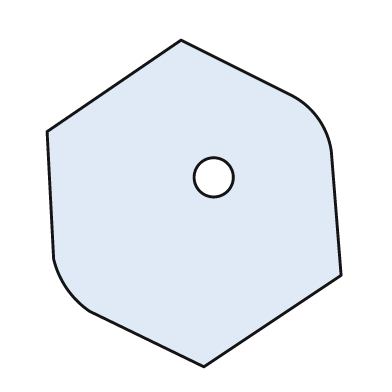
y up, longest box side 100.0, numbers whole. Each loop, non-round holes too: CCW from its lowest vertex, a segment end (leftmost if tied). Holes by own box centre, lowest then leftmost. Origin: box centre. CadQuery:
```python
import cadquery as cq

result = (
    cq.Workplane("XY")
    .moveTo(3.0, -50.0)
    .lineTo(45.0, -22.0)
    .lineTo(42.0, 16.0)
    .threePointArc((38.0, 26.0), (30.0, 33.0))
    .lineTo(-4.0, 50.0)
    .lineTo(-45.0, 22.0)
    .lineTo(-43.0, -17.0)
    .threePointArc((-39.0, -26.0), (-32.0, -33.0))
    .close()
    .moveTo(6.0, 8.0)
    .circle(6.0)
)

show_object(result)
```